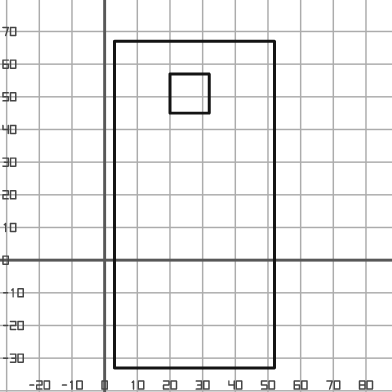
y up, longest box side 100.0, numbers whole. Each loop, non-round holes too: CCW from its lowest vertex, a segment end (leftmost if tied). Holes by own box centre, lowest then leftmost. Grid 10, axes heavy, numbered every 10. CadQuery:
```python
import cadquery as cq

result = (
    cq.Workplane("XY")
    .moveTo(3.0, -33.0)
    .lineTo(52.0, -33.0)
    .lineTo(52.0, 67.0)
    .lineTo(3.0, 67.0)
    .close()
    .moveTo(20.0, 45.0)
    .lineTo(32.0, 45.0)
    .lineTo(32.0, 57.0)
    .lineTo(20.0, 57.0)
    .close()
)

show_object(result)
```